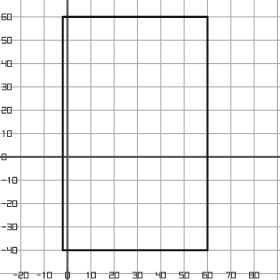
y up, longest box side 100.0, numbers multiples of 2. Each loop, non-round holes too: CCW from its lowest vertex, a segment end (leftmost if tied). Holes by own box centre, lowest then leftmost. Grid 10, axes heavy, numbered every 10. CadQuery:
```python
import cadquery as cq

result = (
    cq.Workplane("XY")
    .moveTo(-2.0, -40.0)
    .lineTo(60.0, -40.0)
    .lineTo(60.0, 60.0)
    .lineTo(-2.0, 60.0)
    .close()
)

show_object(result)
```